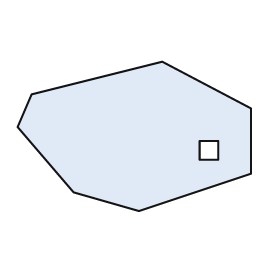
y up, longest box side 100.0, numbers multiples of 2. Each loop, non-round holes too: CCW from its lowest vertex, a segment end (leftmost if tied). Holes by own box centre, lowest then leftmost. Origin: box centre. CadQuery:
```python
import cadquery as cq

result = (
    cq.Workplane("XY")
    .moveTo(2.0, -32.0)
    .lineTo(50.0, -16.0)
    .lineTo(50.0, 12.0)
    .lineTo(12.0, 32.0)
    .lineTo(-44.0, 18.0)
    .lineTo(-50.0, 4.0)
    .lineTo(-26.0, -24.0)
    .close()
    .moveTo(28.0, -10.0)
    .lineTo(36.0, -10.0)
    .lineTo(36.0, -2.0)
    .lineTo(28.0, -2.0)
    .close()
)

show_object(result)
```